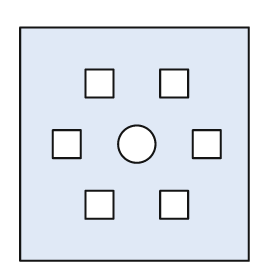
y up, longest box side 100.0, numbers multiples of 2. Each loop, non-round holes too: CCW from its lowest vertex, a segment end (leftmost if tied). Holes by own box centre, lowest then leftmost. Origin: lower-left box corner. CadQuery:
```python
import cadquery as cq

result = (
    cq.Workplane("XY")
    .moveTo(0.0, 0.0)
    .lineTo(98.0, 0.0)
    .lineTo(98.0, 100.0)
    .lineTo(0.0, 100.0)
    .close()
    .moveTo(28.0, 18.0)
    .lineTo(40.0, 18.0)
    .lineTo(40.0, 30.0)
    .lineTo(28.0, 30.0)
    .close()
    .moveTo(60.0, 18.0)
    .lineTo(72.0, 18.0)
    .lineTo(72.0, 30.0)
    .lineTo(60.0, 30.0)
    .close()
    .moveTo(14.0, 44.0)
    .lineTo(26.0, 44.0)
    .lineTo(26.0, 56.0)
    .lineTo(14.0, 56.0)
    .close()
    .moveTo(50.0, 50.0)
    .circle(8.0)
    .moveTo(74.0, 44.0)
    .lineTo(86.0, 44.0)
    .lineTo(86.0, 56.0)
    .lineTo(74.0, 56.0)
    .close()
    .moveTo(28.0, 70.0)
    .lineTo(40.0, 70.0)
    .lineTo(40.0, 82.0)
    .lineTo(28.0, 82.0)
    .close()
    .moveTo(60.0, 70.0)
    .lineTo(72.0, 70.0)
    .lineTo(72.0, 82.0)
    .lineTo(60.0, 82.0)
    .close()
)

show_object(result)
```